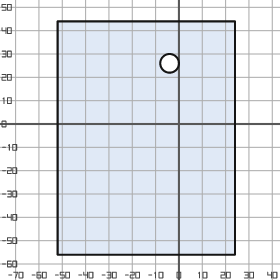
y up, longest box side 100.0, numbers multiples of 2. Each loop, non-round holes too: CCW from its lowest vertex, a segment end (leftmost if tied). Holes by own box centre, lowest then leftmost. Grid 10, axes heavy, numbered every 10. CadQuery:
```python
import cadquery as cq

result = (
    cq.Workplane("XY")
    .moveTo(-52.0, -56.0)
    .lineTo(24.0, -56.0)
    .lineTo(24.0, 44.0)
    .lineTo(-52.0, 44.0)
    .close()
    .moveTo(-4.0, 26.0)
    .circle(4.0)
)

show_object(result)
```